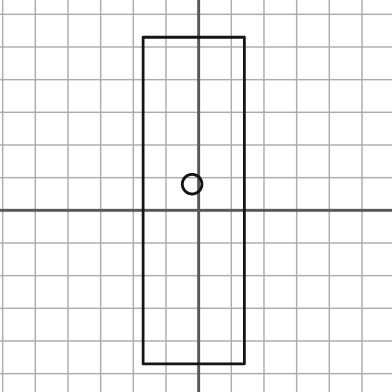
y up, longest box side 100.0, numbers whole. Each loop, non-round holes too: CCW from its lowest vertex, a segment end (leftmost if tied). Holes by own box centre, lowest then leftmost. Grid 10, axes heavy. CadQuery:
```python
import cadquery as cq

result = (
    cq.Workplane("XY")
    .moveTo(-17.0, -47.0)
    .lineTo(14.0, -47.0)
    .lineTo(14.0, 53.0)
    .lineTo(-17.0, 53.0)
    .close()
    .moveTo(-2.0, 8.0)
    .circle(3.0)
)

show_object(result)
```